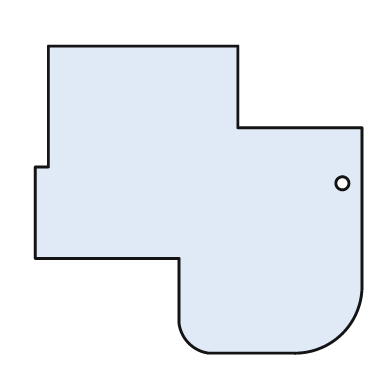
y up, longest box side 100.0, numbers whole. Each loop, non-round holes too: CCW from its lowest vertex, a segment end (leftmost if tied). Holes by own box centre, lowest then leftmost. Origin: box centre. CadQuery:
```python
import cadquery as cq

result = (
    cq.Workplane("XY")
    .moveTo(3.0, -47.0)
    .lineTo(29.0, -47.0)
    .threePointArc((44.0, -41.0), (50.0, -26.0))
    .lineTo(50.0, 22.0)
    .lineTo(12.0, 22.0)
    .lineTo(12.0, 47.0)
    .lineTo(-46.0, 47.0)
    .lineTo(-46.0, 10.0)
    .lineTo(-50.0, 10.0)
    .lineTo(-50.0, -18.0)
    .lineTo(-6.0, -18.0)
    .lineTo(-6.0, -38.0)
    .threePointArc((-3.0, -44.0), (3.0, -47.0))
    .close()
    .moveTo(44.0, 5.0)
    .circle(2.0)
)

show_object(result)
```